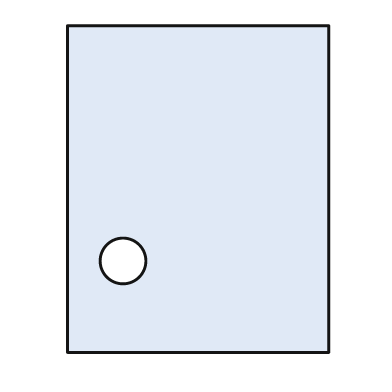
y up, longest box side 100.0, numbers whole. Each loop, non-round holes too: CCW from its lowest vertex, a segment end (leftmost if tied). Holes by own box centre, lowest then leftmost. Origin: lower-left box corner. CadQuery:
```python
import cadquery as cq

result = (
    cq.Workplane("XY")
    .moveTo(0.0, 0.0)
    .lineTo(80.0, 0.0)
    .lineTo(80.0, 100.0)
    .lineTo(0.0, 100.0)
    .close()
    .moveTo(17.0, 28.0)
    .circle(7.0)
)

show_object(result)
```